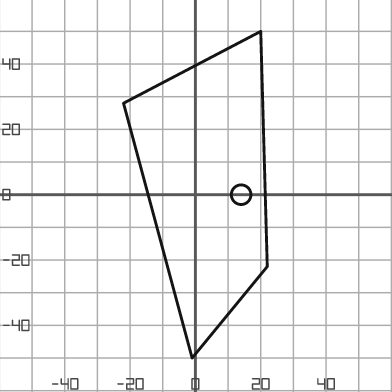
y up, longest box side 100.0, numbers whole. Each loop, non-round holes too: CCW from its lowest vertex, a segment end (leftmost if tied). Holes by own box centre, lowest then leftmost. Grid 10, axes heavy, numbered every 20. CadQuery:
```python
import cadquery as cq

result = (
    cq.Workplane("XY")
    .moveTo(-1.0, -50.0)
    .lineTo(22.0, -22.0)
    .lineTo(20.0, 50.0)
    .lineTo(-22.0, 28.0)
    .close()
    .moveTo(14.0, 0.0)
    .circle(3.0)
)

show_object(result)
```